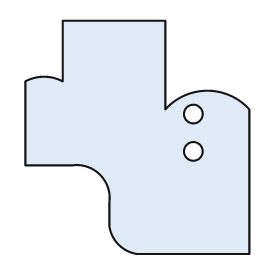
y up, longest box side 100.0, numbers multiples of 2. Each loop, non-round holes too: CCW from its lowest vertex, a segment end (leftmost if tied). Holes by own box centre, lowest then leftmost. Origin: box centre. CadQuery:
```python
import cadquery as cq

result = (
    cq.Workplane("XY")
    .moveTo(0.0, -50.0)
    .lineTo(48.0, -50.0)
    .lineTo(48.0, 12.0)
    .threePointArc((30.0, 20.0), (12.0, 12.0))
    .lineTo(12.0, 50.0)
    .lineTo(-32.0, 50.0)
    .lineTo(-32.0, 24.0)
    .threePointArc((-40.0, 26.0), (-48.0, 24.0))
    .lineTo(-48.0, -12.0)
    .lineTo(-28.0, -12.0)
    .threePointArc((-16.0, -16.0), (-12.0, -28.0))
    .lineTo(-12.0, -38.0)
    .threePointArc((-8.0, -46.0), (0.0, -50.0))
    .close()
    .moveTo(24.0, -6.0)
    .circle(4.0)
    .moveTo(24.0, 10.0)
    .circle(4.0)
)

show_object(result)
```